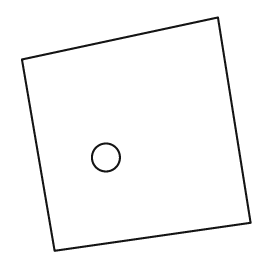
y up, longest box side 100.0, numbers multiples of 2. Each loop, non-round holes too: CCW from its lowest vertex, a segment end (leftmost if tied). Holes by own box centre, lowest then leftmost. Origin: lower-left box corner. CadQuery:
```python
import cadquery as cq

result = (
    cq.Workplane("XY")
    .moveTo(14.0, 0.0)
    .lineTo(98.0, 12.0)
    .lineTo(84.0, 100.0)
    .lineTo(0.0, 82.0)
    .close()
    .moveTo(36.0, 40.0)
    .circle(6.0)
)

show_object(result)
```